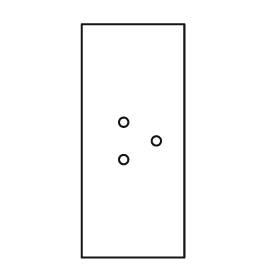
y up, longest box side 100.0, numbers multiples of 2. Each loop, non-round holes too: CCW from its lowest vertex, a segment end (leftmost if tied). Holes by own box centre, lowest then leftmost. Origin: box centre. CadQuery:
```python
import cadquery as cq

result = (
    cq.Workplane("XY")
    .moveTo(-22.0, -50.0)
    .lineTo(22.0, -50.0)
    .lineTo(22.0, 50.0)
    .lineTo(-22.0, 50.0)
    .close()
    .moveTo(-4.0, -8.0)
    .circle(2.0)
    .moveTo(10.0, 0.0)
    .circle(2.0)
    .moveTo(-4.0, 8.0)
    .circle(2.0)
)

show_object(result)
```